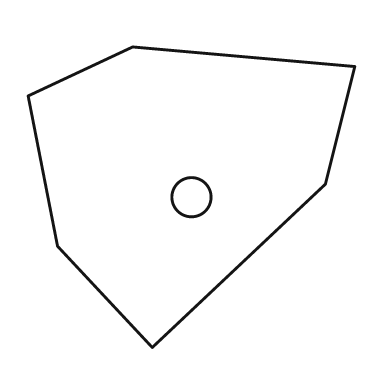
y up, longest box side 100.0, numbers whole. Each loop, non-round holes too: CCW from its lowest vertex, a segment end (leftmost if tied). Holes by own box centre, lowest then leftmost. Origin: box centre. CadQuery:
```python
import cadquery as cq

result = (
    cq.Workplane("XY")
    .moveTo(-12.0, -46.0)
    .lineTo(41.0, 4.0)
    .lineTo(50.0, 40.0)
    .lineTo(-18.0, 46.0)
    .lineTo(-50.0, 31.0)
    .lineTo(-41.0, -15.0)
    .close()
    .moveTo(0.0, 0.0)
    .circle(6.0)
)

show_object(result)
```